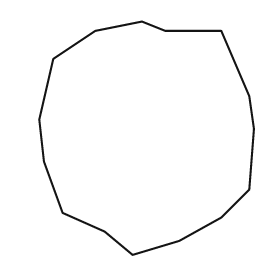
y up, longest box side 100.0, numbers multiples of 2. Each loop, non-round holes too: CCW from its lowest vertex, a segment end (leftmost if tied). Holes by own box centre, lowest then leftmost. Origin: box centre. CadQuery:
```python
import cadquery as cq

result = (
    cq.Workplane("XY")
    .moveTo(-6.0, -50.0)
    .lineTo(14.0, -44.0)
    .lineTo(32.0, -34.0)
    .lineTo(44.0, -22.0)
    .lineTo(46.0, 4.0)
    .lineTo(44.0, 18.0)
    .lineTo(32.0, 46.0)
    .lineTo(8.0, 46.0)
    .lineTo(-2.0, 50.0)
    .lineTo(-22.0, 46.0)
    .lineTo(-40.0, 34.0)
    .lineTo(-46.0, 8.0)
    .lineTo(-44.0, -10.0)
    .lineTo(-36.0, -32.0)
    .lineTo(-18.0, -40.0)
    .close()
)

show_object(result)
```